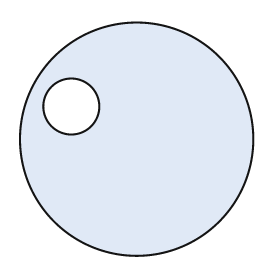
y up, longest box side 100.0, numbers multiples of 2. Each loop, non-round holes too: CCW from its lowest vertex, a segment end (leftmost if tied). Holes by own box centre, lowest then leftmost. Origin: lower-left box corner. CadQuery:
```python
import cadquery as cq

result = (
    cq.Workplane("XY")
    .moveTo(50.0, 50.0)
    .circle(50.0)
    .moveTo(22.0, 64.0)
    .circle(12.0)
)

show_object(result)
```